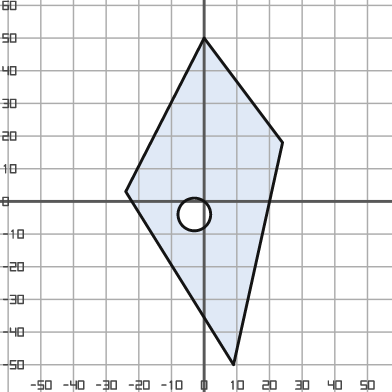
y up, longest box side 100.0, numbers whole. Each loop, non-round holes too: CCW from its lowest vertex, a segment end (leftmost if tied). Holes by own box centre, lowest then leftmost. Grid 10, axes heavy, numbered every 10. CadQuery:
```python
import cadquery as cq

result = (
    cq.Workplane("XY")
    .moveTo(9.0, -50.0)
    .lineTo(24.0, 18.0)
    .lineTo(0.0, 50.0)
    .lineTo(-24.0, 3.0)
    .close()
    .moveTo(-3.0, -4.0)
    .circle(5.0)
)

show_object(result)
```